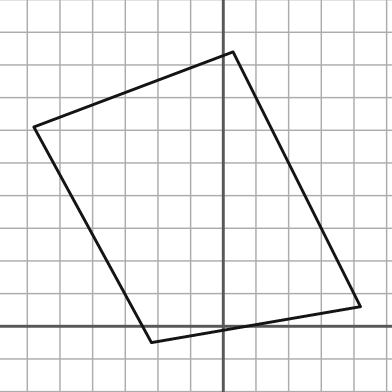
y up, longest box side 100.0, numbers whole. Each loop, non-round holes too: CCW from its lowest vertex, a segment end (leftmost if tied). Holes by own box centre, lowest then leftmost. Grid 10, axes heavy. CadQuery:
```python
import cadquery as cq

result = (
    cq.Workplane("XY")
    .moveTo(-22.0, -5.0)
    .lineTo(42.0, 6.0)
    .lineTo(3.0, 84.0)
    .lineTo(-58.0, 61.0)
    .close()
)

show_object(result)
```